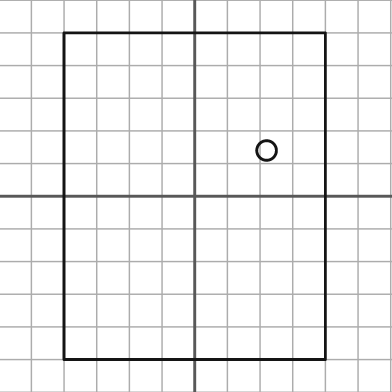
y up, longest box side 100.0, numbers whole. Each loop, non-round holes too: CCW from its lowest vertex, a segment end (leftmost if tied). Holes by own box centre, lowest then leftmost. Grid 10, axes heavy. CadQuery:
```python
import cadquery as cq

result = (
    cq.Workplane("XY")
    .moveTo(-40.0, -50.0)
    .lineTo(40.0, -50.0)
    .lineTo(40.0, 50.0)
    .lineTo(-40.0, 50.0)
    .close()
    .moveTo(22.0, 14.0)
    .circle(3.0)
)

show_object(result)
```